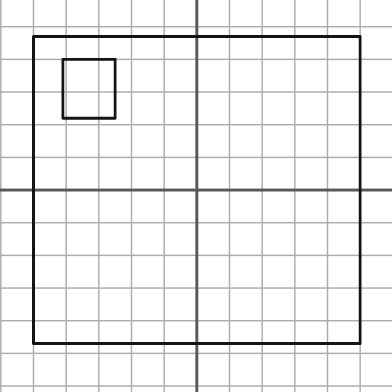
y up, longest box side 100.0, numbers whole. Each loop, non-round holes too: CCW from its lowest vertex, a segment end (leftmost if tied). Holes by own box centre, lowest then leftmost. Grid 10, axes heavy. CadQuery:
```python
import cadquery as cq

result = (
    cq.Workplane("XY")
    .moveTo(-50.0, -47.0)
    .lineTo(50.0, -47.0)
    .lineTo(50.0, 47.0)
    .lineTo(-50.0, 47.0)
    .close()
    .moveTo(-41.0, 22.0)
    .lineTo(-25.0, 22.0)
    .lineTo(-25.0, 40.0)
    .lineTo(-41.0, 40.0)
    .close()
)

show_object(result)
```